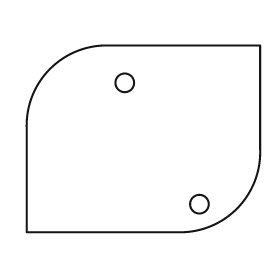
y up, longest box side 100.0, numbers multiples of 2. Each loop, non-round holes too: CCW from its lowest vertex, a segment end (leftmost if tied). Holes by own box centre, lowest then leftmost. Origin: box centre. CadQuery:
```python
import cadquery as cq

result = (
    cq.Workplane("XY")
    .moveTo(-50.0, -40.0)
    .lineTo(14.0, -40.0)
    .threePointArc((40.0, -30.0), (50.0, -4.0))
    .lineTo(50.0, 40.0)
    .lineTo(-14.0, 40.0)
    .threePointArc((-40.0, 30.0), (-50.0, 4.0))
    .close()
    .moveTo(24.0, -28.0)
    .circle(4.0)
    .moveTo(-8.0, 24.0)
    .circle(4.0)
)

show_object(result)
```